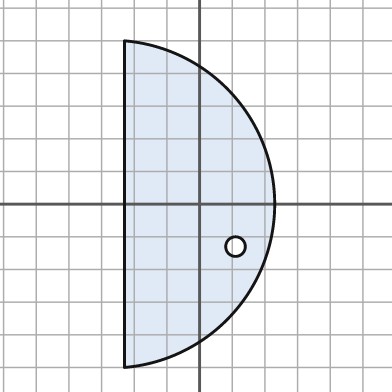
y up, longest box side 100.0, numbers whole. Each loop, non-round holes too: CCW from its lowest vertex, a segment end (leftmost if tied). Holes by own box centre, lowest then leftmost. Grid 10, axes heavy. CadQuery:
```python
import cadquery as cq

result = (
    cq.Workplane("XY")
    .moveTo(-23.0, -50.0)
    .threePointArc((23.0, 0.0), (-23.0, 50.0))
    .close()
    .moveTo(11.0, -13.0)
    .circle(3.0)
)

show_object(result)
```